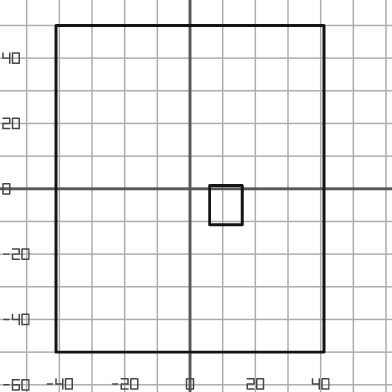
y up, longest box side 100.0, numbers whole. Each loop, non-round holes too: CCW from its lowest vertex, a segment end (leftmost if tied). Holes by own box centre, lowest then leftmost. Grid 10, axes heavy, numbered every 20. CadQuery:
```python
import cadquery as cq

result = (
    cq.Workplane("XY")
    .moveTo(-41.0, -50.0)
    .lineTo(41.0, -50.0)
    .lineTo(41.0, 50.0)
    .lineTo(-41.0, 50.0)
    .close()
    .moveTo(6.0, -11.0)
    .lineTo(16.0, -11.0)
    .lineTo(16.0, 1.0)
    .lineTo(6.0, 1.0)
    .close()
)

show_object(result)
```